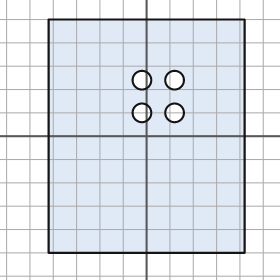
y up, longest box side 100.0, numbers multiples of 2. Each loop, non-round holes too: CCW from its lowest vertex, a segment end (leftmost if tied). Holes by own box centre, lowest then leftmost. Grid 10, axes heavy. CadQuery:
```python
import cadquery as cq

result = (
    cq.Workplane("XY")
    .moveTo(-42.0, -50.0)
    .lineTo(42.0, -50.0)
    .lineTo(42.0, 50.0)
    .lineTo(-42.0, 50.0)
    .close()
    .moveTo(-2.0, 10.0)
    .circle(4.0)
    .moveTo(12.0, 10.0)
    .circle(4.0)
    .moveTo(-2.0, 24.0)
    .circle(4.0)
    .moveTo(12.0, 24.0)
    .circle(4.0)
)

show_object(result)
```